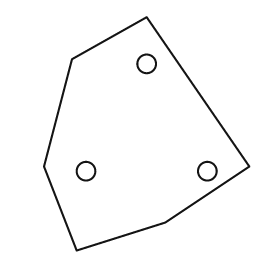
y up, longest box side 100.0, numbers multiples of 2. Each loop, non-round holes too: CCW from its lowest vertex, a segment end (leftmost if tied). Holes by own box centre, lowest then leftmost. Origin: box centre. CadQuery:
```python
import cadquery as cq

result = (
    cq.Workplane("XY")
    .moveTo(-30.0, -50.0)
    .lineTo(8.0, -38.0)
    .lineTo(44.0, -14.0)
    .lineTo(0.0, 50.0)
    .lineTo(-32.0, 32.0)
    .lineTo(-44.0, -14.0)
    .close()
    .moveTo(-26.0, -16.0)
    .circle(4.0)
    .moveTo(26.0, -16.0)
    .circle(4.0)
    .moveTo(0.0, 30.0)
    .circle(4.0)
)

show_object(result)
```